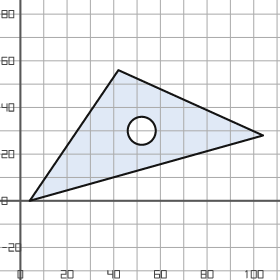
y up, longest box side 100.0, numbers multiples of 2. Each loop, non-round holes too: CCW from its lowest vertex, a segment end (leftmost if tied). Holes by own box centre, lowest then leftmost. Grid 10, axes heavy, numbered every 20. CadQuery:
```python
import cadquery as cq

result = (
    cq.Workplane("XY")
    .moveTo(4.0, 0.0)
    .lineTo(104.0, 28.0)
    .lineTo(42.0, 56.0)
    .close()
    .moveTo(52.0, 30.0)
    .circle(6.0)
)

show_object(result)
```